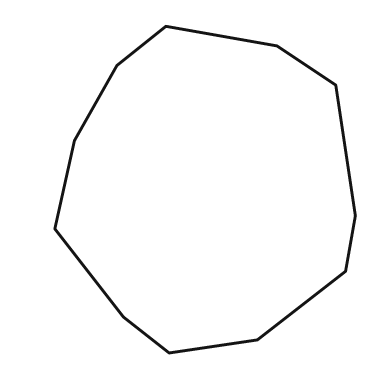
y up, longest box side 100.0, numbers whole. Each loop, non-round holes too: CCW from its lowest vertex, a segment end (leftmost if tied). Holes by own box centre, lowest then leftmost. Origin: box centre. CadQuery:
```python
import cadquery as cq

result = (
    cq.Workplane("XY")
    .moveTo(-11.0, -50.0)
    .lineTo(16.0, -46.0)
    .lineTo(43.0, -25.0)
    .lineTo(46.0, -8.0)
    .lineTo(40.0, 32.0)
    .lineTo(22.0, 44.0)
    .lineTo(-12.0, 50.0)
    .lineTo(-27.0, 38.0)
    .lineTo(-40.0, 15.0)
    .lineTo(-46.0, -12.0)
    .lineTo(-25.0, -39.0)
    .close()
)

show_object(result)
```